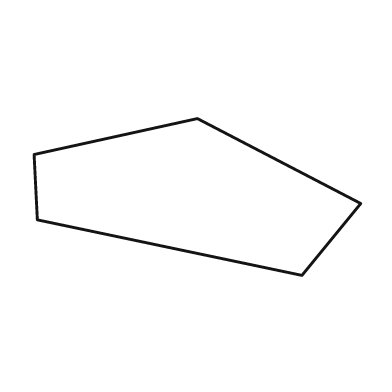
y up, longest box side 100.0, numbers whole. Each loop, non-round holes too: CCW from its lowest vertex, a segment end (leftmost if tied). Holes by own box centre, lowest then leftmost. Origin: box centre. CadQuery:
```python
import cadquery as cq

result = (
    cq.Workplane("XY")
    .moveTo(32.0, -24.0)
    .lineTo(50.0, -2.0)
    .lineTo(0.0, 24.0)
    .lineTo(-50.0, 13.0)
    .lineTo(-49.0, -7.0)
    .close()
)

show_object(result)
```